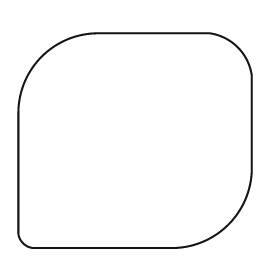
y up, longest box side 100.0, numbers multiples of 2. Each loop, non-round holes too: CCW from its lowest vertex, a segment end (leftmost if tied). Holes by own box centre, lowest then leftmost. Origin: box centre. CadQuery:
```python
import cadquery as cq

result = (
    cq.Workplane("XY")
    .moveTo(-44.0, -46.0)
    .lineTo(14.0, -46.0)
    .threePointArc((40.0, -36.0), (50.0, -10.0))
    .lineTo(50.0, 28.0)
    .threePointArc((44.0, 40.0), (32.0, 46.0))
    .lineTo(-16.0, 46.0)
    .threePointArc((-40.0, 36.0), (-50.0, 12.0))
    .lineTo(-50.0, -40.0)
    .threePointArc((-48.0, -44.0), (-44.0, -46.0))
    .close()
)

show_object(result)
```